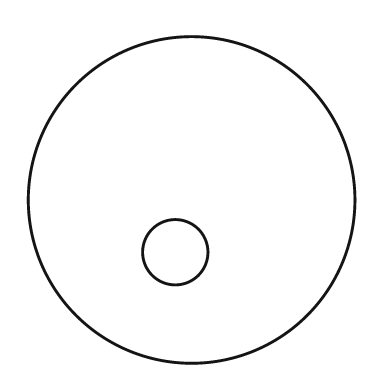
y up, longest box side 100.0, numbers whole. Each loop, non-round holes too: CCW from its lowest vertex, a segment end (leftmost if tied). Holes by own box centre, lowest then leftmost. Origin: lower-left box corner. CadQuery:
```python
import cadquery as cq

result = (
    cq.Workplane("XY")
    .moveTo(50.0, 50.0)
    .circle(50.0)
    .moveTo(45.0, 34.0)
    .circle(10.0)
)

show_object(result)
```